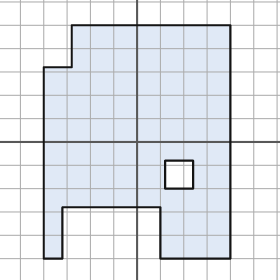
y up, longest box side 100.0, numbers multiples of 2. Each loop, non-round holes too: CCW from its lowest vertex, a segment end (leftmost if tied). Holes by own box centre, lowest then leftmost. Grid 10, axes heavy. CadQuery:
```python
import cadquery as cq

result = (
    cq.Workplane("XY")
    .moveTo(-40.0, -50.0)
    .lineTo(-32.0, -50.0)
    .lineTo(-32.0, -28.0)
    .lineTo(10.0, -28.0)
    .lineTo(10.0, -50.0)
    .lineTo(40.0, -50.0)
    .lineTo(40.0, 50.0)
    .lineTo(-28.0, 50.0)
    .lineTo(-28.0, 32.0)
    .lineTo(-40.0, 32.0)
    .close()
    .moveTo(12.0, -20.0)
    .lineTo(24.0, -20.0)
    .lineTo(24.0, -8.0)
    .lineTo(12.0, -8.0)
    .close()
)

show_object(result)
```